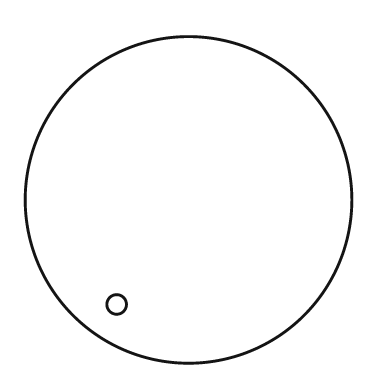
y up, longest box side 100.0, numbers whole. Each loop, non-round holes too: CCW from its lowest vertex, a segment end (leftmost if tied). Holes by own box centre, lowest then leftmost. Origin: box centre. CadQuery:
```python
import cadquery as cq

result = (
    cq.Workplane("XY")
    .moveTo(0.0, 0.0)
    .circle(50.0)
    .moveTo(-22.0, -32.0)
    .circle(3.0)
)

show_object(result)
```